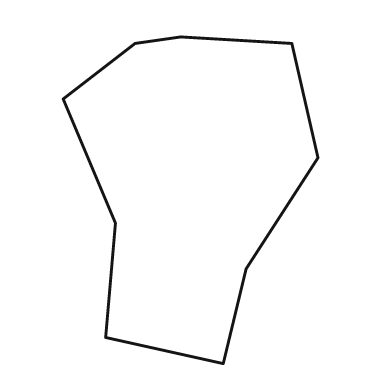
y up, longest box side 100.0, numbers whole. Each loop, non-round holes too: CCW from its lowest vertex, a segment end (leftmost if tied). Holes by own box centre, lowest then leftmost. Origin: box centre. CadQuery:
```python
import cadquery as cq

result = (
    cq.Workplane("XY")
    .moveTo(10.0, -50.0)
    .lineTo(17.0, -21.0)
    .lineTo(39.0, 13.0)
    .lineTo(31.0, 48.0)
    .lineTo(-3.0, 50.0)
    .lineTo(-17.0, 48.0)
    .lineTo(-39.0, 31.0)
    .lineTo(-23.0, -7.0)
    .lineTo(-26.0, -42.0)
    .close()
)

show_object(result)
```